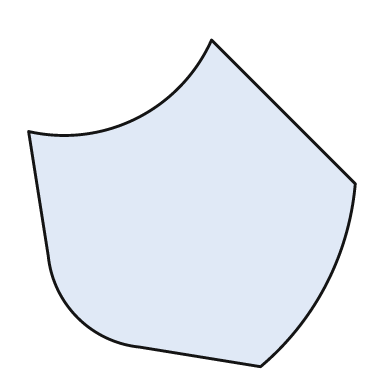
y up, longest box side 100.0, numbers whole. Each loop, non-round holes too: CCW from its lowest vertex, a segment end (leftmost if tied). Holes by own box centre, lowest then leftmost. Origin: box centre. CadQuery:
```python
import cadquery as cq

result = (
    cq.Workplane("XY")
    .moveTo(21.0, -50.0)
    .threePointArc((41.0, -25.0), (50.0, 6.0))
    .lineTo(6.0, 50.0)
    .threePointArc((-17.0, 26.0), (-50.0, 22.0))
    .lineTo(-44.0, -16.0)
    .threePointArc((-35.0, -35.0), (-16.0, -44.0))
    .close()
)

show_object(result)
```